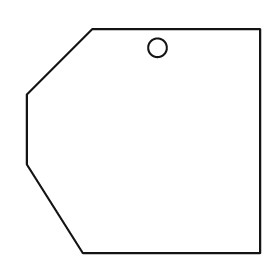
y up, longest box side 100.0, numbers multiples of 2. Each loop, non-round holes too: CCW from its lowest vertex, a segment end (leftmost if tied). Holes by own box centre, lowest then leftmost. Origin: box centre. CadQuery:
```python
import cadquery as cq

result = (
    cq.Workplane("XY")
    .moveTo(-26.0, -48.0)
    .lineTo(50.0, -48.0)
    .lineTo(50.0, 48.0)
    .lineTo(-22.0, 48.0)
    .lineTo(-50.0, 20.0)
    .lineTo(-50.0, -10.0)
    .close()
    .moveTo(6.0, 40.0)
    .circle(4.0)
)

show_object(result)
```